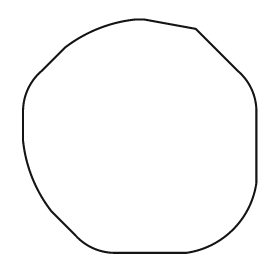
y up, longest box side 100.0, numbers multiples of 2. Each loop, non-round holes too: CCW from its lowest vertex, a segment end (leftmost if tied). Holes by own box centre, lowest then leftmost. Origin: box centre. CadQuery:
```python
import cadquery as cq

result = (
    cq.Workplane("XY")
    .moveTo(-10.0, -50.0)
    .lineTo(20.0, -50.0)
    .threePointArc((40.0, -40.0), (50.0, -20.0))
    .lineTo(50.0, 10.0)
    .threePointArc((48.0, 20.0), (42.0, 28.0))
    .lineTo(24.0, 46.0)
    .lineTo(2.0, 50.0)
    .lineTo(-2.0, 50.0)
    .threePointArc((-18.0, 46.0), (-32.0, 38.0))
    .lineTo(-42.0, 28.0)
    .threePointArc((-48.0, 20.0), (-50.0, 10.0))
    .lineTo(-50.0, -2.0)
    .threePointArc((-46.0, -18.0), (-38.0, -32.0))
    .lineTo(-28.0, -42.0)
    .threePointArc((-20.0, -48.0), (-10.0, -50.0))
    .close()
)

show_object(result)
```